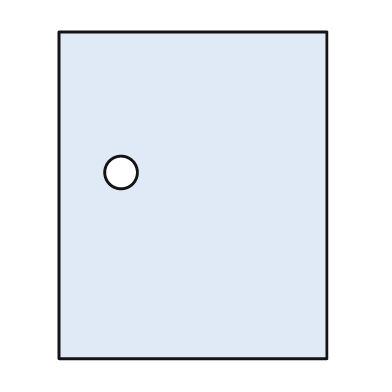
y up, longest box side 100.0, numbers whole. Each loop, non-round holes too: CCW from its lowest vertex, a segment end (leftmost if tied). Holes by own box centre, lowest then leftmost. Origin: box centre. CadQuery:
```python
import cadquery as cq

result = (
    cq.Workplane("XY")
    .moveTo(-41.0, -50.0)
    .lineTo(41.0, -50.0)
    .lineTo(41.0, 50.0)
    .lineTo(-41.0, 50.0)
    .close()
    .moveTo(-22.0, 7.0)
    .circle(5.0)
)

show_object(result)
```